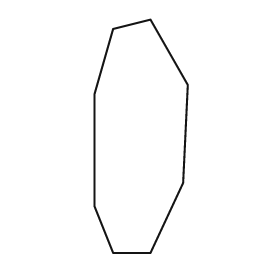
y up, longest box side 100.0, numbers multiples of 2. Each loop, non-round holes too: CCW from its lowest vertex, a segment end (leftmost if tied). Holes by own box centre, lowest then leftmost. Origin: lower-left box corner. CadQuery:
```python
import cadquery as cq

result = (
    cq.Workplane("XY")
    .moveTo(8.0, 0.0)
    .lineTo(24.0, 0.0)
    .lineTo(38.0, 30.0)
    .lineTo(40.0, 72.0)
    .lineTo(24.0, 100.0)
    .lineTo(8.0, 96.0)
    .lineTo(0.0, 68.0)
    .lineTo(0.0, 20.0)
    .close()
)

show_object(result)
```